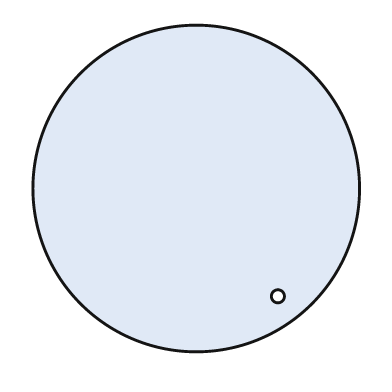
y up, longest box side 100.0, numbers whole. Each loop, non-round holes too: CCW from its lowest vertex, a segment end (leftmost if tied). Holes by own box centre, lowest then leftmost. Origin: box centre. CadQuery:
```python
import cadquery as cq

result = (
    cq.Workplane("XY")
    .moveTo(0.0, 0.0)
    .circle(50.0)
    .moveTo(25.0, -33.0)
    .circle(2.0)
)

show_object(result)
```